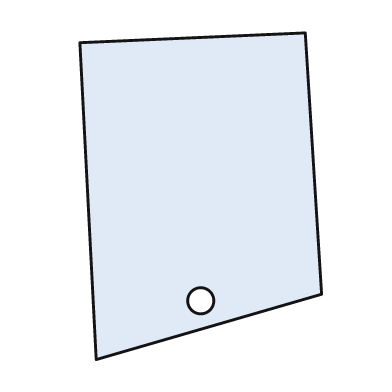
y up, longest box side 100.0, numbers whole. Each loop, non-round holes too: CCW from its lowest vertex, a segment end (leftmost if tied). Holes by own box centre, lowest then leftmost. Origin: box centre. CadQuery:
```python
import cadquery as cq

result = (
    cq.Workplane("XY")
    .moveTo(-32.0, -50.0)
    .lineTo(37.0, -30.0)
    .lineTo(32.0, 50.0)
    .lineTo(-37.0, 47.0)
    .close()
    .moveTo(0.0, -32.0)
    .circle(4.0)
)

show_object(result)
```